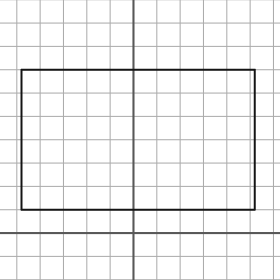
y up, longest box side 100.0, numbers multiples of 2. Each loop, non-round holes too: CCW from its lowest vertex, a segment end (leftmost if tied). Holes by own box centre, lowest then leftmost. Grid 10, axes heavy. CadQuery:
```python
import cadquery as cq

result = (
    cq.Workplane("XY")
    .moveTo(-48.0, 10.0)
    .lineTo(52.0, 10.0)
    .lineTo(52.0, 70.0)
    .lineTo(-48.0, 70.0)
    .close()
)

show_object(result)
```